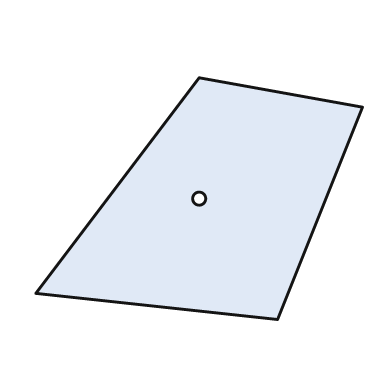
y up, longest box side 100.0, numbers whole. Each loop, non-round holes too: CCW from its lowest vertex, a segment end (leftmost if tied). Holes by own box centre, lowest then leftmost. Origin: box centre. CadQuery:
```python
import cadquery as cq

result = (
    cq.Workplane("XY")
    .moveTo(24.0, -37.0)
    .lineTo(50.0, 28.0)
    .lineTo(0.0, 37.0)
    .lineTo(-50.0, -29.0)
    .close()
    .moveTo(0.0, 0.0)
    .circle(2.0)
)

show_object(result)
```